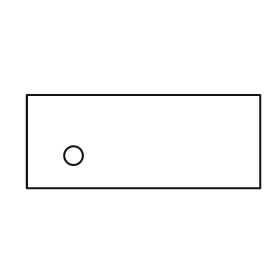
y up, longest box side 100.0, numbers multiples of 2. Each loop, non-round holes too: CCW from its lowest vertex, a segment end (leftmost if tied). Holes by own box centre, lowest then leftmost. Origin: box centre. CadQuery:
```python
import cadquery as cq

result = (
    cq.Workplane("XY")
    .moveTo(-50.0, -20.0)
    .lineTo(50.0, -20.0)
    .lineTo(50.0, 20.0)
    .lineTo(-50.0, 20.0)
    .close()
    .moveTo(-30.0, -6.0)
    .circle(4.0)
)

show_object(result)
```